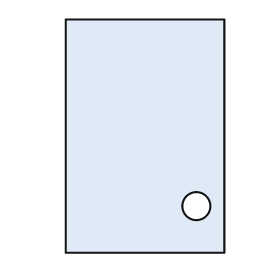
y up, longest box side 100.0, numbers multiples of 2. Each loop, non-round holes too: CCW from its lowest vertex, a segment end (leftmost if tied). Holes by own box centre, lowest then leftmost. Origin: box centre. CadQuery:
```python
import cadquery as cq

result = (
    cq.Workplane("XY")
    .moveTo(-34.0, -50.0)
    .lineTo(34.0, -50.0)
    .lineTo(34.0, 50.0)
    .lineTo(-34.0, 50.0)
    .close()
    .moveTo(22.0, -30.0)
    .circle(6.0)
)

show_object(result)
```